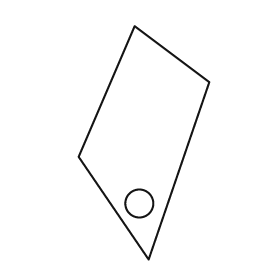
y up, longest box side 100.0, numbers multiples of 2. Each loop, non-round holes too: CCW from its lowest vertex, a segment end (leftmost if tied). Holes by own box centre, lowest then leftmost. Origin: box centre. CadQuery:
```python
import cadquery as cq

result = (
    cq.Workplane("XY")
    .moveTo(2.0, -50.0)
    .lineTo(28.0, 26.0)
    .lineTo(-4.0, 50.0)
    .lineTo(-28.0, -6.0)
    .close()
    .moveTo(-2.0, -26.0)
    .circle(6.0)
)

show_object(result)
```